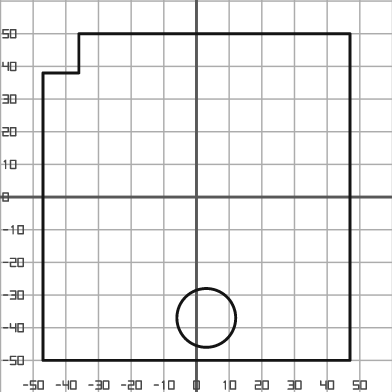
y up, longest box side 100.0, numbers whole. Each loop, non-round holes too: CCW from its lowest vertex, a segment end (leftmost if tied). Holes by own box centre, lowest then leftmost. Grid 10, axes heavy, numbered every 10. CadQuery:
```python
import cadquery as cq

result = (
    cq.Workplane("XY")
    .moveTo(-47.0, -50.0)
    .lineTo(47.0, -50.0)
    .lineTo(47.0, 50.0)
    .lineTo(-36.0, 50.0)
    .lineTo(-36.0, 38.0)
    .lineTo(-47.0, 38.0)
    .close()
    .moveTo(3.0, -37.0)
    .circle(9.0)
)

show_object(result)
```